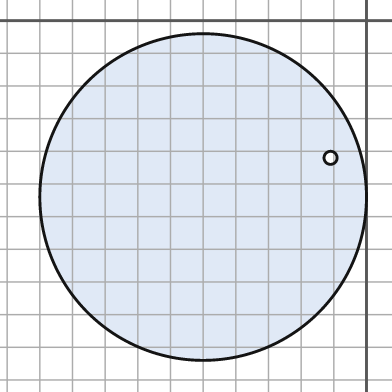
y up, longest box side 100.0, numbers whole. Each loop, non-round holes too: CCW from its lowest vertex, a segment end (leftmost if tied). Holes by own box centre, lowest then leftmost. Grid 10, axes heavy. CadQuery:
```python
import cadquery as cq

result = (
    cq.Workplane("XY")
    .moveTo(-50.0, -54.0)
    .circle(50.0)
    .moveTo(-11.0, -42.0)
    .circle(2.0)
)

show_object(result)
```